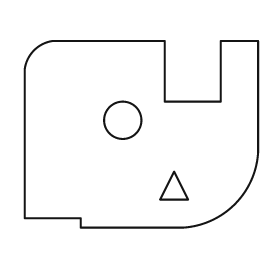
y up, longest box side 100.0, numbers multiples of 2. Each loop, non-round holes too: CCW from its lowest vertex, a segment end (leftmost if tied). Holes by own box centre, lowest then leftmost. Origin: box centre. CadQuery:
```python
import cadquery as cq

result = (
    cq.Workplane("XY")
    .moveTo(-26.0, -40.0)
    .lineTo(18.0, -40.0)
    .threePointArc((40.0, -30.0), (50.0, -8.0))
    .lineTo(50.0, 40.0)
    .lineTo(34.0, 40.0)
    .lineTo(34.0, 14.0)
    .lineTo(10.0, 14.0)
    .lineTo(10.0, 40.0)
    .lineTo(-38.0, 40.0)
    .threePointArc((-46.0, 36.0), (-50.0, 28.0))
    .lineTo(-50.0, -36.0)
    .lineTo(-26.0, -36.0)
    .close()
    .moveTo(8.0, -28.0)
    .lineTo(20.0, -28.0)
    .lineTo(14.0, -16.0)
    .close()
    .moveTo(-8.0, 6.0)
    .circle(8.0)
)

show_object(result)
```